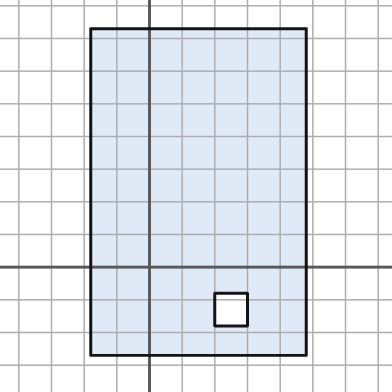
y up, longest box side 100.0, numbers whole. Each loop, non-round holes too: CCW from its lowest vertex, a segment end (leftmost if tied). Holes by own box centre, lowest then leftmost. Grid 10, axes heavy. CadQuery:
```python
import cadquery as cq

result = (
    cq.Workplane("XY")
    .moveTo(-18.0, -27.0)
    .lineTo(48.0, -27.0)
    .lineTo(48.0, 73.0)
    .lineTo(-18.0, 73.0)
    .close()
    .moveTo(20.0, -18.0)
    .lineTo(30.0, -18.0)
    .lineTo(30.0, -8.0)
    .lineTo(20.0, -8.0)
    .close()
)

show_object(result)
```